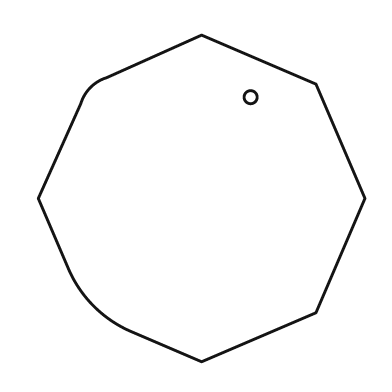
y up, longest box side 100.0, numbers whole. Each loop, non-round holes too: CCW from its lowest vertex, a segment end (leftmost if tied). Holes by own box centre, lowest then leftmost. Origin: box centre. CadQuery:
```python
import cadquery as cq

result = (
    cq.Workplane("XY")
    .moveTo(0.0, -50.0)
    .lineTo(35.0, -35.0)
    .lineTo(50.0, 0.0)
    .lineTo(35.0, 35.0)
    .lineTo(0.0, 50.0)
    .lineTo(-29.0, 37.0)
    .threePointArc((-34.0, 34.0), (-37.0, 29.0))
    .lineTo(-50.0, 0.0)
    .lineTo(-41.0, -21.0)
    .threePointArc((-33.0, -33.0), (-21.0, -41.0))
    .close()
    .moveTo(15.0, 31.0)
    .circle(2.0)
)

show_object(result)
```